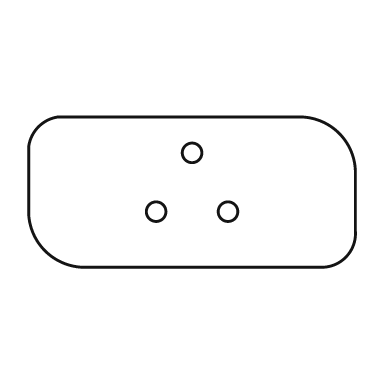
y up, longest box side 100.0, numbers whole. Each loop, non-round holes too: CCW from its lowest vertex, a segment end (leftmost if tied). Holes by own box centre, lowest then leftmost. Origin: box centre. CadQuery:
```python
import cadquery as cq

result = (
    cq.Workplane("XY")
    .moveTo(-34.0, -23.0)
    .lineTo(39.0, -23.0)
    .threePointArc((47.0, -20.0), (50.0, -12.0))
    .lineTo(50.0, 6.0)
    .threePointArc((45.0, 18.0), (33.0, 23.0))
    .lineTo(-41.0, 23.0)
    .threePointArc((-47.0, 20.0), (-50.0, 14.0))
    .lineTo(-50.0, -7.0)
    .threePointArc((-45.0, -18.0), (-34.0, -23.0))
    .close()
    .moveTo(-11.0, -6.0)
    .circle(3.0)
    .moveTo(11.0, -6.0)
    .circle(3.0)
    .moveTo(0.0, 12.0)
    .circle(3.0)
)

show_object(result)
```